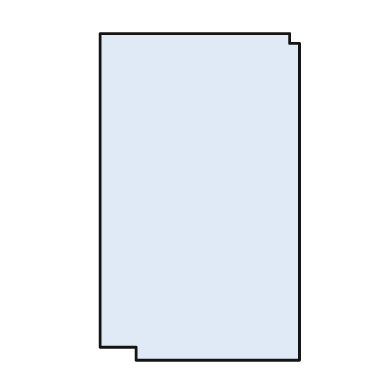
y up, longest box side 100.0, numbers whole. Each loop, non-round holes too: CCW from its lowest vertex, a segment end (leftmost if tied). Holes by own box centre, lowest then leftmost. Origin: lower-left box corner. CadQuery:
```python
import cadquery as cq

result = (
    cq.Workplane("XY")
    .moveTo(11.0, 0.0)
    .lineTo(61.0, 0.0)
    .lineTo(61.0, 97.0)
    .lineTo(58.0, 97.0)
    .lineTo(58.0, 100.0)
    .lineTo(0.0, 100.0)
    .lineTo(0.0, 4.0)
    .lineTo(11.0, 4.0)
    .close()
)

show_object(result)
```